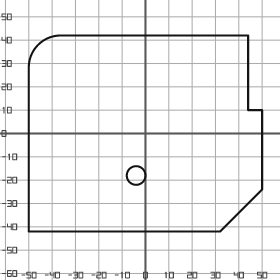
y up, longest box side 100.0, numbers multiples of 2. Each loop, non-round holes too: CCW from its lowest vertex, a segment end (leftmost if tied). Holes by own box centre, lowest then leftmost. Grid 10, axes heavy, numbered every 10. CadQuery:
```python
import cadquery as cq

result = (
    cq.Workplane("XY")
    .moveTo(-50.0, -42.0)
    .lineTo(32.0, -42.0)
    .lineTo(50.0, -24.0)
    .lineTo(50.0, 10.0)
    .lineTo(44.0, 10.0)
    .lineTo(44.0, 42.0)
    .lineTo(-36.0, 42.0)
    .threePointArc((-46.0, 38.0), (-50.0, 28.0))
    .close()
    .moveTo(-4.0, -18.0)
    .circle(4.0)
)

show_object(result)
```